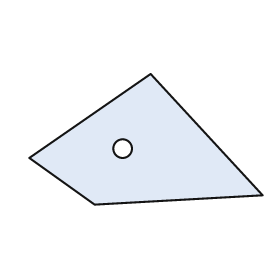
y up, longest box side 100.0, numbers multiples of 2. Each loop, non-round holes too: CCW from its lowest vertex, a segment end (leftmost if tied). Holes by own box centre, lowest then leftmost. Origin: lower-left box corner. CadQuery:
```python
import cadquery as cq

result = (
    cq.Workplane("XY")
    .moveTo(28.0, 0.0)
    .lineTo(100.0, 4.0)
    .lineTo(52.0, 56.0)
    .lineTo(0.0, 20.0)
    .close()
    .moveTo(40.0, 24.0)
    .circle(4.0)
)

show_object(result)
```